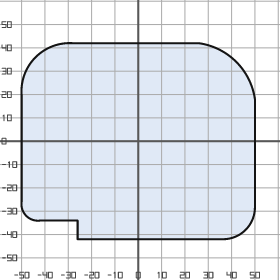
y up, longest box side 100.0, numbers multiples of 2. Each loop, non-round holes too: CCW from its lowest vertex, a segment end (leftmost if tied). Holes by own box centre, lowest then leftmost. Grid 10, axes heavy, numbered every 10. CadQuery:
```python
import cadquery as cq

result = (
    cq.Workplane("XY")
    .moveTo(-26.0, -42.0)
    .lineTo(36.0, -42.0)
    .threePointArc((46.0, -38.0), (50.0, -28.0))
    .lineTo(50.0, 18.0)
    .threePointArc((42.0, 34.0), (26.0, 42.0))
    .lineTo(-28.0, 42.0)
    .threePointArc((-44.0, 36.0), (-50.0, 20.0))
    .lineTo(-50.0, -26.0)
    .threePointArc((-48.0, -32.0), (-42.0, -34.0))
    .lineTo(-26.0, -34.0)
    .close()
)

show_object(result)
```